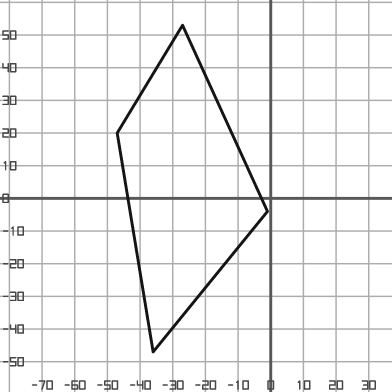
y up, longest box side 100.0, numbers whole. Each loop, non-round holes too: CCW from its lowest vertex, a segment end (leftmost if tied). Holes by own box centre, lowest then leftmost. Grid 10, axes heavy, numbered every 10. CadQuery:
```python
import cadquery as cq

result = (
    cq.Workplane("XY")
    .moveTo(-36.0, -47.0)
    .lineTo(-1.0, -4.0)
    .lineTo(-27.0, 53.0)
    .lineTo(-47.0, 20.0)
    .close()
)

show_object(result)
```